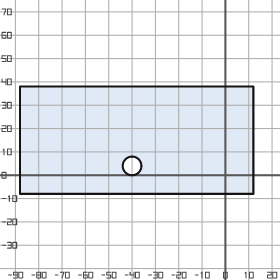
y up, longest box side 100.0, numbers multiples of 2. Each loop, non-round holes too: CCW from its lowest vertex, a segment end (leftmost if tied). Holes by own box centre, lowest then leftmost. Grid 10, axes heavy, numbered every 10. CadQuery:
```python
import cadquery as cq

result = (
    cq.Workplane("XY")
    .moveTo(-88.0, -8.0)
    .lineTo(12.0, -8.0)
    .lineTo(12.0, 38.0)
    .lineTo(-88.0, 38.0)
    .close()
    .moveTo(-40.0, 4.0)
    .circle(4.0)
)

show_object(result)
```